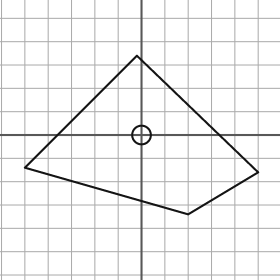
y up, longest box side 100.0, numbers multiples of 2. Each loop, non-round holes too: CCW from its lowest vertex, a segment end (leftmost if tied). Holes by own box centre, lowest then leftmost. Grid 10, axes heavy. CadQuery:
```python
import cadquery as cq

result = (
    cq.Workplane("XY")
    .moveTo(20.0, -34.0)
    .lineTo(50.0, -16.0)
    .lineTo(-2.0, 34.0)
    .lineTo(-50.0, -14.0)
    .close()
    .moveTo(0.0, 0.0)
    .circle(4.0)
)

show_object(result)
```